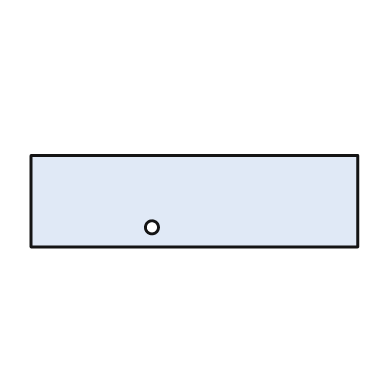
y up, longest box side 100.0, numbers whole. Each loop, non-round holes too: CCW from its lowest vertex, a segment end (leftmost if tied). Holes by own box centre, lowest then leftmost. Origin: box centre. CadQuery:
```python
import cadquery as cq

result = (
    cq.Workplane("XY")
    .moveTo(-50.0, -14.0)
    .lineTo(50.0, -14.0)
    .lineTo(50.0, 14.0)
    .lineTo(-50.0, 14.0)
    .close()
    .moveTo(-13.0, -8.0)
    .circle(2.0)
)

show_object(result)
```